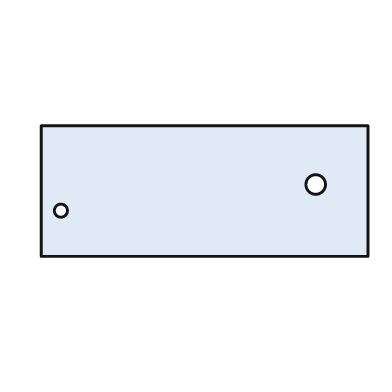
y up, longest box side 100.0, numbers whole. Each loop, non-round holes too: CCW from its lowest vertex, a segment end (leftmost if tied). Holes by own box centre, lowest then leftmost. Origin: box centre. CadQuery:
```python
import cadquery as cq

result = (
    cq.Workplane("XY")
    .moveTo(-50.0, -20.0)
    .lineTo(50.0, -20.0)
    .lineTo(50.0, 20.0)
    .lineTo(-50.0, 20.0)
    .close()
    .moveTo(-44.0, -6.0)
    .circle(2.0)
    .moveTo(34.0, 2.0)
    .circle(3.0)
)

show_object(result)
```